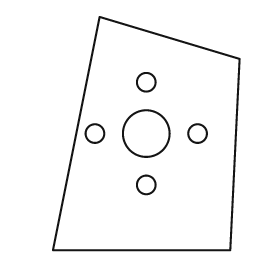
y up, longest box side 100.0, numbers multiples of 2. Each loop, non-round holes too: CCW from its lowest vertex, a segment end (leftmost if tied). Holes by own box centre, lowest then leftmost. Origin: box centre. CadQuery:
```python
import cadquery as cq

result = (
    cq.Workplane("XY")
    .moveTo(-40.0, -50.0)
    .lineTo(36.0, -50.0)
    .lineTo(40.0, 32.0)
    .lineTo(-20.0, 50.0)
    .close()
    .moveTo(0.0, -22.0)
    .circle(4.0)
    .moveTo(-22.0, 0.0)
    .circle(4.0)
    .moveTo(0.0, 0.0)
    .circle(10.0)
    .moveTo(22.0, 0.0)
    .circle(4.0)
    .moveTo(0.0, 22.0)
    .circle(4.0)
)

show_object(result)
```